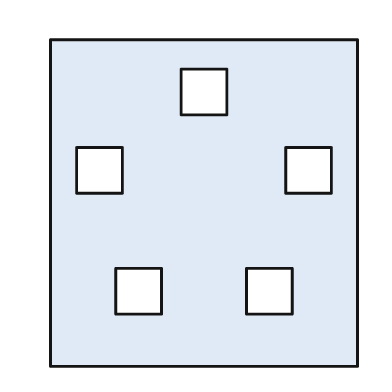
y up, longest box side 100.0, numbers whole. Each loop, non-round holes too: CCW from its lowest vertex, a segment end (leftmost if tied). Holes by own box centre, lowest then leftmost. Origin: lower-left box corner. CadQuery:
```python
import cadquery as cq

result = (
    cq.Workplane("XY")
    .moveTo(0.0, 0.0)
    .lineTo(94.0, 0.0)
    .lineTo(94.0, 100.0)
    .lineTo(0.0, 100.0)
    .close()
    .moveTo(20.0, 16.0)
    .lineTo(34.0, 16.0)
    .lineTo(34.0, 30.0)
    .lineTo(20.0, 30.0)
    .close()
    .moveTo(60.0, 16.0)
    .lineTo(74.0, 16.0)
    .lineTo(74.0, 30.0)
    .lineTo(60.0, 30.0)
    .close()
    .moveTo(8.0, 53.0)
    .lineTo(22.0, 53.0)
    .lineTo(22.0, 67.0)
    .lineTo(8.0, 67.0)
    .close()
    .moveTo(72.0, 53.0)
    .lineTo(86.0, 53.0)
    .lineTo(86.0, 67.0)
    .lineTo(72.0, 67.0)
    .close()
    .moveTo(40.0, 77.0)
    .lineTo(54.0, 77.0)
    .lineTo(54.0, 91.0)
    .lineTo(40.0, 91.0)
    .close()
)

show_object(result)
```